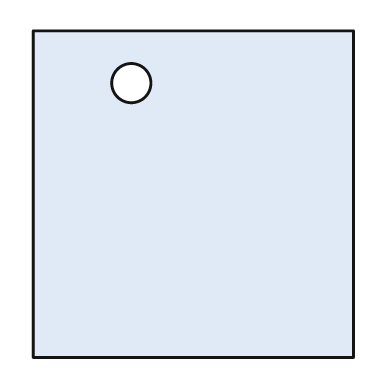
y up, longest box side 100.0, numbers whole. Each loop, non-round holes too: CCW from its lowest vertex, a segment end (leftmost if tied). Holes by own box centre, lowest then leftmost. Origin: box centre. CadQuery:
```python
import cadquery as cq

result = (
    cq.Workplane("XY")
    .moveTo(-49.0, -50.0)
    .lineTo(49.0, -50.0)
    .lineTo(49.0, 50.0)
    .lineTo(-49.0, 50.0)
    .close()
    .moveTo(-19.0, 34.0)
    .circle(6.0)
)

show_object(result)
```